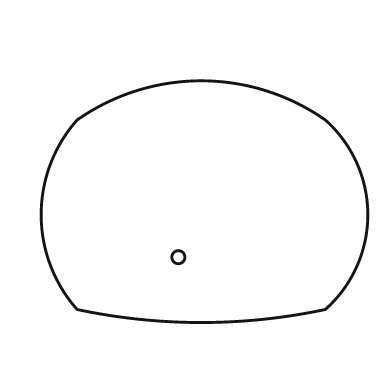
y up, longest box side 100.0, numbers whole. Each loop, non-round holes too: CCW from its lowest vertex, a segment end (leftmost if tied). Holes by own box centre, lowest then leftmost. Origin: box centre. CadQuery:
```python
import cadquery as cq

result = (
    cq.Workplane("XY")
    .moveTo(-39.0, -33.0)
    .threePointArc((-1.0, -37.0), (37.0, -33.0))
    .threePointArc((50.0, -4.0), (37.0, 25.0))
    .threePointArc((-1.0, 37.0), (-39.0, 25.0))
    .threePointArc((-50.0, -4.0), (-39.0, -33.0))
    .close()
    .moveTo(-8.0, -17.0)
    .circle(2.0)
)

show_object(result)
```